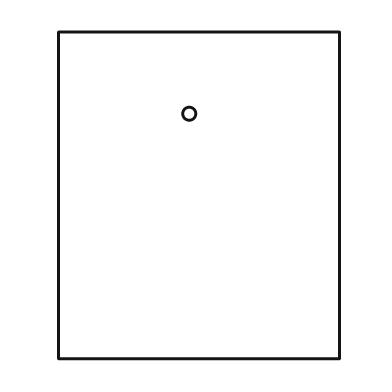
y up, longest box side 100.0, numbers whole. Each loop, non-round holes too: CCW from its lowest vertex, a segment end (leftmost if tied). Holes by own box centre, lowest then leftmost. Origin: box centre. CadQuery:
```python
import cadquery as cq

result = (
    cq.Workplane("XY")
    .moveTo(-43.0, -50.0)
    .lineTo(43.0, -50.0)
    .lineTo(43.0, 50.0)
    .lineTo(-43.0, 50.0)
    .close()
    .moveTo(-3.0, 25.0)
    .circle(2.0)
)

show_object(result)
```